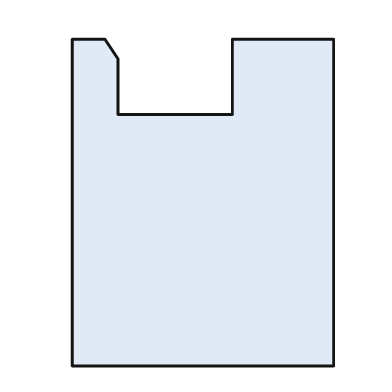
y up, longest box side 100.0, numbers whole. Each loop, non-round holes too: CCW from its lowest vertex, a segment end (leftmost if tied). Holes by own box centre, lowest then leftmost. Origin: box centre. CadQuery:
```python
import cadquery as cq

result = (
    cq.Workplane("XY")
    .moveTo(-40.0, -50.0)
    .lineTo(40.0, -50.0)
    .lineTo(40.0, 50.0)
    .lineTo(9.0, 50.0)
    .lineTo(9.0, 27.0)
    .lineTo(-26.0, 27.0)
    .lineTo(-26.0, 44.0)
    .lineTo(-30.0, 50.0)
    .lineTo(-40.0, 50.0)
    .close()
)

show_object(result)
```